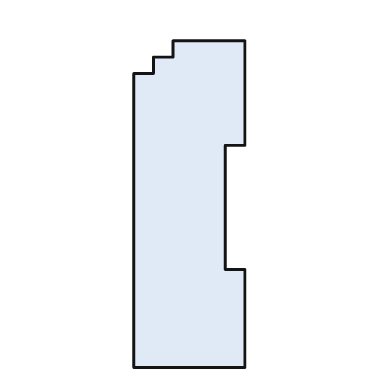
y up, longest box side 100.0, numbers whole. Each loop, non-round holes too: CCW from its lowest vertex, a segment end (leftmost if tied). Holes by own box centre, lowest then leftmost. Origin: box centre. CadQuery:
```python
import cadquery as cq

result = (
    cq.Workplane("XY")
    .moveTo(-17.0, -50.0)
    .lineTo(17.0, -50.0)
    .lineTo(17.0, -20.0)
    .lineTo(11.0, -20.0)
    .lineTo(11.0, 18.0)
    .lineTo(17.0, 18.0)
    .lineTo(17.0, 50.0)
    .lineTo(-5.0, 50.0)
    .lineTo(-5.0, 45.0)
    .lineTo(-11.0, 45.0)
    .lineTo(-11.0, 40.0)
    .lineTo(-17.0, 40.0)
    .close()
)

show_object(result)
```